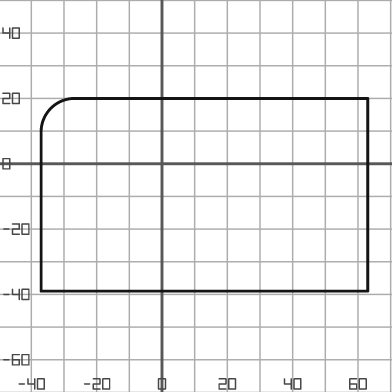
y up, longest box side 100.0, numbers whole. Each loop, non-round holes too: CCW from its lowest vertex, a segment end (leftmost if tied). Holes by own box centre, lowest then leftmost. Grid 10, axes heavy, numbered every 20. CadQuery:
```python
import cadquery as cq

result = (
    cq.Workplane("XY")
    .moveTo(-37.0, -39.0)
    .lineTo(63.0, -39.0)
    .lineTo(63.0, 20.0)
    .lineTo(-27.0, 20.0)
    .threePointArc((-34.0, 17.0), (-37.0, 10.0))
    .close()
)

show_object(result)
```